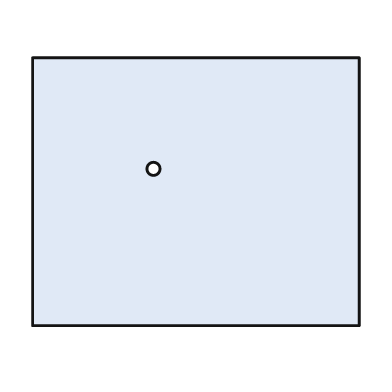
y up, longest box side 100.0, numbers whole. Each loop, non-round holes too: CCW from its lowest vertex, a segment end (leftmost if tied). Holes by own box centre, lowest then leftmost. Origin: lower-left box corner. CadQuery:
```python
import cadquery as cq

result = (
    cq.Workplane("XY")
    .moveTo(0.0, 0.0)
    .lineTo(100.0, 0.0)
    .lineTo(100.0, 82.0)
    .lineTo(0.0, 82.0)
    .close()
    .moveTo(37.0, 48.0)
    .circle(2.0)
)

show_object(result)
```